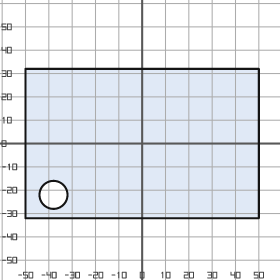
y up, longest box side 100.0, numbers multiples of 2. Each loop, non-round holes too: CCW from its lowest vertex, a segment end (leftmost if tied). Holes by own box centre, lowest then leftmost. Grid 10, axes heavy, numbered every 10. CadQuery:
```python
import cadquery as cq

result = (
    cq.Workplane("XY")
    .moveTo(-50.0, -32.0)
    .lineTo(50.0, -32.0)
    .lineTo(50.0, 32.0)
    .lineTo(-50.0, 32.0)
    .close()
    .moveTo(-38.0, -22.0)
    .circle(6.0)
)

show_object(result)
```